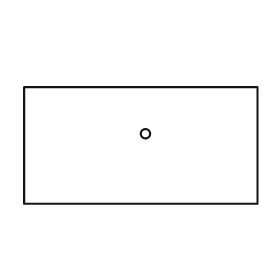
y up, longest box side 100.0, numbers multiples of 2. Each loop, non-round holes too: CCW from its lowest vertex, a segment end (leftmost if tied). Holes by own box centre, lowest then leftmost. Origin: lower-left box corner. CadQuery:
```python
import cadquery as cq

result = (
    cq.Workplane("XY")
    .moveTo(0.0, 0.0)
    .lineTo(100.0, 0.0)
    .lineTo(100.0, 50.0)
    .lineTo(0.0, 50.0)
    .close()
    .moveTo(52.0, 30.0)
    .circle(2.0)
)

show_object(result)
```